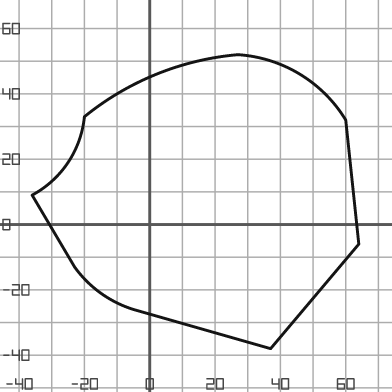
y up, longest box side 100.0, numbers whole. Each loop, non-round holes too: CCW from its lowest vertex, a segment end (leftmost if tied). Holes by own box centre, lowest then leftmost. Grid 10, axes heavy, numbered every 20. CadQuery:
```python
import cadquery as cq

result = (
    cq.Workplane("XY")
    .moveTo(37.0, -38.0)
    .lineTo(64.0, -6.0)
    .lineTo(60.0, 32.0)
    .threePointArc((46.0, 46.0), (27.0, 52.0))
    .threePointArc((2.0, 46.0), (-20.0, 33.0))
    .threePointArc((-25.0, 19.0), (-36.0, 9.0))
    .lineTo(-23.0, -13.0)
    .threePointArc((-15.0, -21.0), (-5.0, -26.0))
    .close()
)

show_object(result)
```